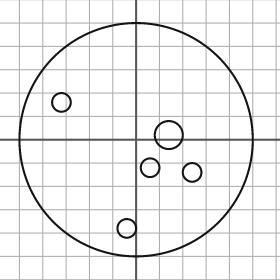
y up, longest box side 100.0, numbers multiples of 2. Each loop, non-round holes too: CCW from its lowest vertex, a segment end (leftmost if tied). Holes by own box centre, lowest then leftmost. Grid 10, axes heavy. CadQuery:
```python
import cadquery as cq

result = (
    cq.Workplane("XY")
    .moveTo(0.0, 0.0)
    .circle(50.0)
    .moveTo(-4.0, -38.0)
    .circle(4.0)
    .moveTo(24.0, -14.0)
    .circle(4.0)
    .moveTo(6.0, -12.0)
    .circle(4.0)
    .moveTo(14.0, 2.0)
    .circle(6.0)
    .moveTo(-32.0, 16.0)
    .circle(4.0)
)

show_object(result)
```